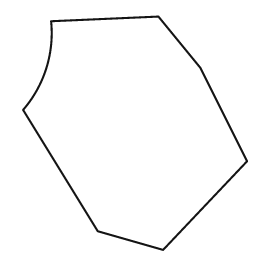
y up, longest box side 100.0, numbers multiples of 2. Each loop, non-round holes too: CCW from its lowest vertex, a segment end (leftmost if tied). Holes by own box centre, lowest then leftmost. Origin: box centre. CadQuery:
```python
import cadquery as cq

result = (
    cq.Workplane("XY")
    .moveTo(12.0, -50.0)
    .lineTo(48.0, -12.0)
    .lineTo(28.0, 28.0)
    .lineTo(10.0, 50.0)
    .lineTo(-36.0, 48.0)
    .threePointArc((-38.0, 28.0), (-48.0, 10.0))
    .lineTo(-16.0, -42.0)
    .close()
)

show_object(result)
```